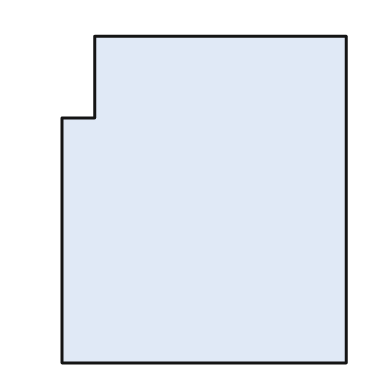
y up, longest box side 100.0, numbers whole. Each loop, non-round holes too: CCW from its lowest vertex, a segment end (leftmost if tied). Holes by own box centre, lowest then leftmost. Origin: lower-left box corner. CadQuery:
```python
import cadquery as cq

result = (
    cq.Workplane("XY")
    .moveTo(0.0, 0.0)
    .lineTo(87.0, 0.0)
    .lineTo(87.0, 100.0)
    .lineTo(10.0, 100.0)
    .lineTo(10.0, 75.0)
    .lineTo(0.0, 75.0)
    .close()
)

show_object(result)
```